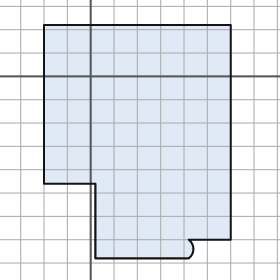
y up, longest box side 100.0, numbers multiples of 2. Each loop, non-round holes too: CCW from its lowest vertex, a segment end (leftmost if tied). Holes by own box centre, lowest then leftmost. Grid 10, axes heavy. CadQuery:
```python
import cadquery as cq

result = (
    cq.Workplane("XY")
    .moveTo(2.0, -78.0)
    .lineTo(42.0, -78.0)
    .threePointArc((44.0, -74.0), (42.0, -70.0))
    .lineTo(60.0, -70.0)
    .lineTo(60.0, 22.0)
    .lineTo(-20.0, 22.0)
    .lineTo(-20.0, -46.0)
    .lineTo(2.0, -46.0)
    .close()
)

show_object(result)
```